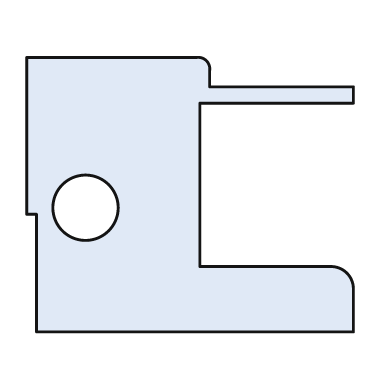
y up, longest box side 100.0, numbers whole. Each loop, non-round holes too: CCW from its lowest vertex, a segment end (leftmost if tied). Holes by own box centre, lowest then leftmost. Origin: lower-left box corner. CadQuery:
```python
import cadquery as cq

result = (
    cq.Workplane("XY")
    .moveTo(3.0, 0.0)
    .lineTo(100.0, 0.0)
    .lineTo(100.0, 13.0)
    .threePointArc((98.0, 18.0), (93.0, 20.0))
    .lineTo(53.0, 20.0)
    .lineTo(53.0, 70.0)
    .lineTo(100.0, 70.0)
    .lineTo(100.0, 75.0)
    .lineTo(56.0, 75.0)
    .lineTo(56.0, 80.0)
    .threePointArc((55.0, 83.0), (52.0, 84.0))
    .lineTo(0.0, 84.0)
    .lineTo(0.0, 36.0)
    .lineTo(3.0, 36.0)
    .close()
    .moveTo(18.0, 38.0)
    .circle(10.0)
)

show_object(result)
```